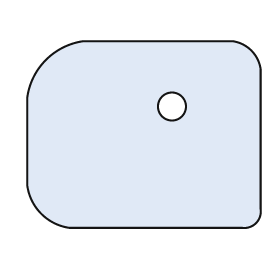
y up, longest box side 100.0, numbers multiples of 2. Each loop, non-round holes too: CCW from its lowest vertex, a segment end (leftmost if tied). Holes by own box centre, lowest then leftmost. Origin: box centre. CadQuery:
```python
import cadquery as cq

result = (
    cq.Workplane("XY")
    .moveTo(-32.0, -40.0)
    .lineTo(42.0, -40.0)
    .threePointArc((48.0, -38.0), (50.0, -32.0))
    .lineTo(50.0, 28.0)
    .threePointArc((46.0, 36.0), (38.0, 40.0))
    .lineTo(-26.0, 40.0)
    .threePointArc((-42.0, 32.0), (-50.0, 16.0))
    .lineTo(-50.0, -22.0)
    .threePointArc((-44.0, -34.0), (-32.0, -40.0))
    .close()
    .moveTo(12.0, 12.0)
    .circle(6.0)
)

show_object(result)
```